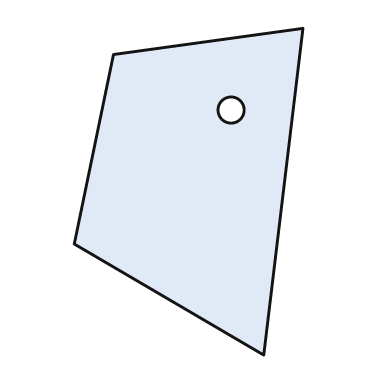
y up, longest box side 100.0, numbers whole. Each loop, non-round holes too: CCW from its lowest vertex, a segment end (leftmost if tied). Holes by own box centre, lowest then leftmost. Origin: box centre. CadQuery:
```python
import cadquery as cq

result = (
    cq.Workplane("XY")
    .moveTo(23.0, -50.0)
    .lineTo(35.0, 50.0)
    .lineTo(-23.0, 42.0)
    .lineTo(-35.0, -16.0)
    .close()
    .moveTo(13.0, 25.0)
    .circle(4.0)
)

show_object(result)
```